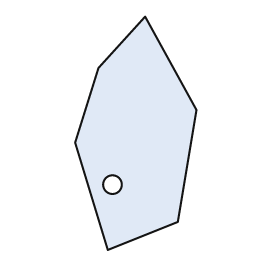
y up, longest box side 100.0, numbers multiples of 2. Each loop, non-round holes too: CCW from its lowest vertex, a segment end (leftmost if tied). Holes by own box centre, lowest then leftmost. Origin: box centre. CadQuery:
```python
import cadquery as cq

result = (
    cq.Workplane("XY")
    .moveTo(-12.0, -50.0)
    .lineTo(18.0, -38.0)
    .lineTo(26.0, 10.0)
    .lineTo(4.0, 50.0)
    .lineTo(-16.0, 28.0)
    .lineTo(-26.0, -4.0)
    .close()
    .moveTo(-10.0, -22.0)
    .circle(4.0)
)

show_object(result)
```